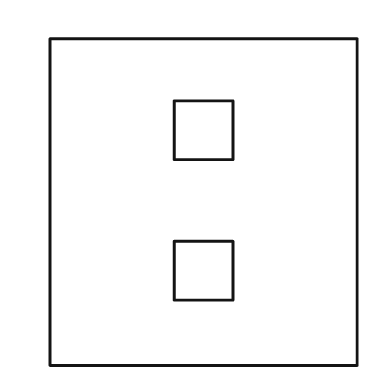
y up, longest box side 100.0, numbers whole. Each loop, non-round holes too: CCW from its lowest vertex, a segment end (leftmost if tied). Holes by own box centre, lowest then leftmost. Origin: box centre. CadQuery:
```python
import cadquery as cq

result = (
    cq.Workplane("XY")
    .moveTo(-47.0, -50.0)
    .lineTo(47.0, -50.0)
    .lineTo(47.0, 50.0)
    .lineTo(-47.0, 50.0)
    .close()
    .moveTo(-9.0, -30.0)
    .lineTo(9.0, -30.0)
    .lineTo(9.0, -12.0)
    .lineTo(-9.0, -12.0)
    .close()
    .moveTo(-9.0, 13.0)
    .lineTo(9.0, 13.0)
    .lineTo(9.0, 31.0)
    .lineTo(-9.0, 31.0)
    .close()
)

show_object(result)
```